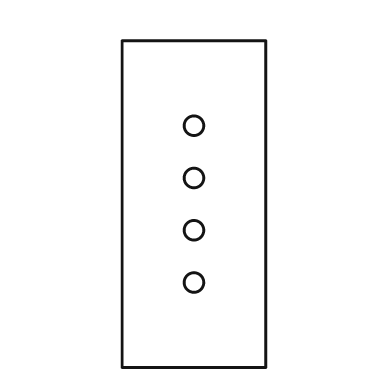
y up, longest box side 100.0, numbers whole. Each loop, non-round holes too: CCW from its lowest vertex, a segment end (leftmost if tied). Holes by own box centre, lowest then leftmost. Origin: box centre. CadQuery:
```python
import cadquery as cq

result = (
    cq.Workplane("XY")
    .moveTo(-22.0, -50.0)
    .lineTo(22.0, -50.0)
    .lineTo(22.0, 50.0)
    .lineTo(-22.0, 50.0)
    .close()
    .moveTo(0.0, -24.0)
    .circle(3.0)
    .moveTo(0.0, -8.0)
    .circle(3.0)
    .moveTo(0.0, 8.0)
    .circle(3.0)
    .moveTo(0.0, 24.0)
    .circle(3.0)
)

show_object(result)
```